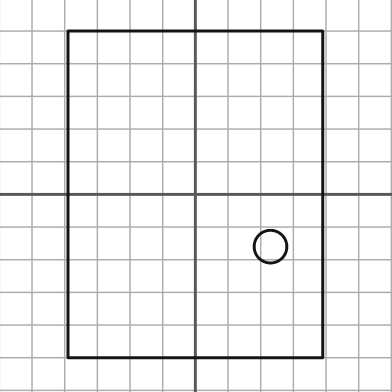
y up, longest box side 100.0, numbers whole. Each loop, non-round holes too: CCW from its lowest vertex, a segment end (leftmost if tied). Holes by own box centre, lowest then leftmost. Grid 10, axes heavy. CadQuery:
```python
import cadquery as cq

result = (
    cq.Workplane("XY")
    .moveTo(-39.0, -50.0)
    .lineTo(39.0, -50.0)
    .lineTo(39.0, 50.0)
    .lineTo(-39.0, 50.0)
    .close()
    .moveTo(23.0, -16.0)
    .circle(5.0)
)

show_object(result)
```